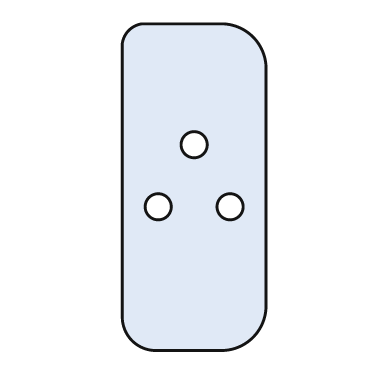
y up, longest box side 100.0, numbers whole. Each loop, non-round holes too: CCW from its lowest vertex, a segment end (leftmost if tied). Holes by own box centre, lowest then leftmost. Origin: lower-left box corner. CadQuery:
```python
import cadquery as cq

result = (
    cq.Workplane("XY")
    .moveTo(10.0, 0.0)
    .lineTo(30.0, 0.0)
    .threePointArc((40.0, 4.0), (44.0, 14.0))
    .lineTo(44.0, 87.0)
    .threePointArc((40.0, 96.0), (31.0, 100.0))
    .lineTo(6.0, 100.0)
    .threePointArc((2.0, 98.0), (0.0, 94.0))
    .lineTo(0.0, 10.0)
    .threePointArc((3.0, 3.0), (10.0, 0.0))
    .close()
    .moveTo(11.0, 44.0)
    .circle(4.0)
    .moveTo(33.0, 44.0)
    .circle(4.0)
    .moveTo(22.0, 63.0)
    .circle(4.0)
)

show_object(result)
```